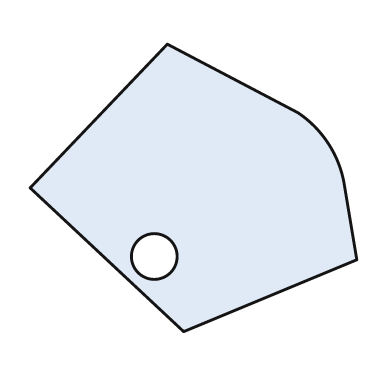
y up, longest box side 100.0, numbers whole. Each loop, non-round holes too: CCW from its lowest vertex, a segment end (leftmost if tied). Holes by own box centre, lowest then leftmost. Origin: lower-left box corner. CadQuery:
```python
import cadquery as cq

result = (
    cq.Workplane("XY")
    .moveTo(47.0, 0.0)
    .lineTo(100.0, 22.0)
    .lineTo(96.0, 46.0)
    .threePointArc((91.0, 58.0), (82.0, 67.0))
    .lineTo(42.0, 88.0)
    .lineTo(0.0, 44.0)
    .close()
    .moveTo(38.0, 23.0)
    .circle(7.0)
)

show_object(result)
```